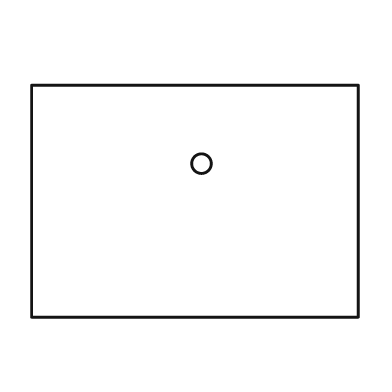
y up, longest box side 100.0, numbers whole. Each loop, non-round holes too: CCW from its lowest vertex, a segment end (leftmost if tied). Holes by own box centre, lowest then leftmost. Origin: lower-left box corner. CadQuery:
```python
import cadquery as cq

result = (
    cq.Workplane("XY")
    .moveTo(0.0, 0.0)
    .lineTo(100.0, 0.0)
    .lineTo(100.0, 71.0)
    .lineTo(0.0, 71.0)
    .close()
    .moveTo(52.0, 47.0)
    .circle(3.0)
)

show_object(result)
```